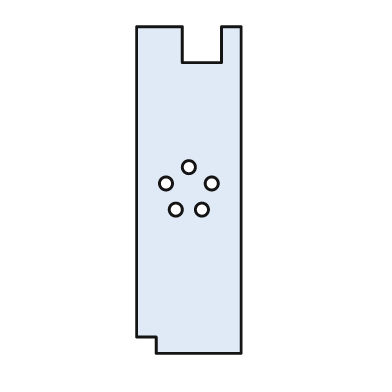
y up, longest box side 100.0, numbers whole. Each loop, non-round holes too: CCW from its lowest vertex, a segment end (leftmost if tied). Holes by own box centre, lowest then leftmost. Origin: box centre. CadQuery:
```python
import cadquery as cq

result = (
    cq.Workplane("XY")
    .moveTo(-10.0, -50.0)
    .lineTo(16.0, -50.0)
    .lineTo(16.0, 50.0)
    .lineTo(10.0, 50.0)
    .lineTo(10.0, 39.0)
    .lineTo(-2.0, 39.0)
    .lineTo(-2.0, 50.0)
    .lineTo(-16.0, 50.0)
    .lineTo(-16.0, -45.0)
    .lineTo(-10.0, -45.0)
    .close()
    .moveTo(-4.0, -6.0)
    .circle(2.0)
    .moveTo(4.0, -6.0)
    .circle(2.0)
    .moveTo(-7.0, 2.0)
    .circle(2.0)
    .moveTo(7.0, 2.0)
    .circle(2.0)
    .moveTo(0.0, 7.0)
    .circle(2.0)
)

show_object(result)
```